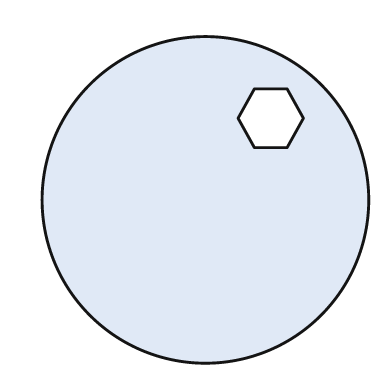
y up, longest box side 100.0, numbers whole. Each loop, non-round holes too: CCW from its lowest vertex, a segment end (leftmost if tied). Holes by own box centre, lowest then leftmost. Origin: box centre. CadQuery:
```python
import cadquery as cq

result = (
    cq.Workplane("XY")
    .moveTo(0.0, 0.0)
    .circle(50.0)
    .moveTo(15.0, 16.0)
    .lineTo(25.0, 16.0)
    .lineTo(30.0, 25.0)
    .lineTo(25.0, 34.0)
    .lineTo(15.0, 34.0)
    .lineTo(10.0, 25.0)
    .close()
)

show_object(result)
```